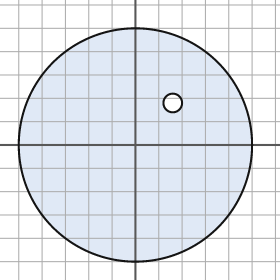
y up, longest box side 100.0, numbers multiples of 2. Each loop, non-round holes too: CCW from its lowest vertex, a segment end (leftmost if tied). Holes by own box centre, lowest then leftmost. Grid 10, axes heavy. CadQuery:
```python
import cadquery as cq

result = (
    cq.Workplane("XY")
    .moveTo(0.0, 0.0)
    .circle(50.0)
    .moveTo(16.0, 18.0)
    .circle(4.0)
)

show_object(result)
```